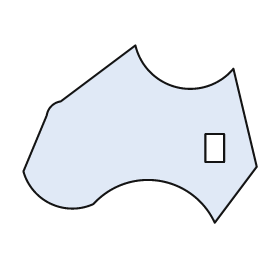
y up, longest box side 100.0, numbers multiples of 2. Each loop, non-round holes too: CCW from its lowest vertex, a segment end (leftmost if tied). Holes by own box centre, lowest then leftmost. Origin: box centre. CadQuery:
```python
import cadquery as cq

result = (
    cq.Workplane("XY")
    .moveTo(32.0, -38.0)
    .lineTo(50.0, -14.0)
    .lineTo(40.0, 28.0)
    .threePointArc((16.0, 20.0), (-2.0, 38.0))
    .lineTo(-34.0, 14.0)
    .threePointArc((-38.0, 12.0), (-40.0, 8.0))
    .lineTo(-50.0, -16.0)
    .threePointArc((-38.0, -30.0), (-20.0, -30.0))
    .threePointArc((8.0, -20.0), (32.0, -38.0))
    .close()
    .moveTo(28.0, -12.0)
    .lineTo(36.0, -12.0)
    .lineTo(36.0, 0.0)
    .lineTo(28.0, 0.0)
    .close()
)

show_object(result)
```